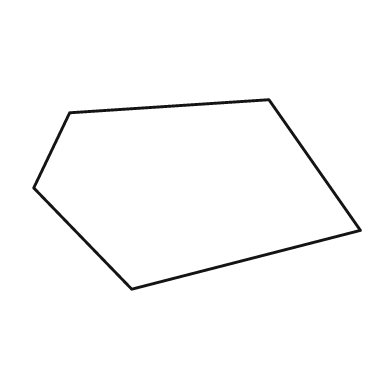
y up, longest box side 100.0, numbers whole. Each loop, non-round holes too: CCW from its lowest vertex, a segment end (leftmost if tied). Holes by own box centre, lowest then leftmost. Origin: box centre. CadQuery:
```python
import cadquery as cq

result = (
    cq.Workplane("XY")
    .moveTo(-20.0, -29.0)
    .lineTo(50.0, -11.0)
    .lineTo(22.0, 29.0)
    .lineTo(-39.0, 25.0)
    .lineTo(-50.0, 2.0)
    .close()
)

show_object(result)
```